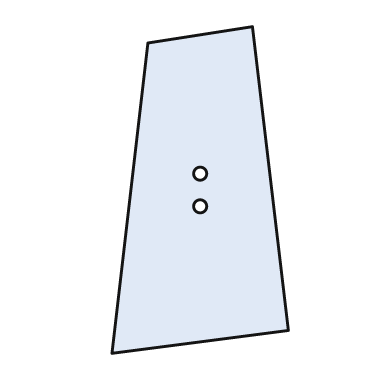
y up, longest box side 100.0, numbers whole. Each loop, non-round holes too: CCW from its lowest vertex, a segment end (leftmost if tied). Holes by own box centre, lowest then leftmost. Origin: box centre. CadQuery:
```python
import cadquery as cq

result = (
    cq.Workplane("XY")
    .moveTo(-27.0, -50.0)
    .lineTo(27.0, -43.0)
    .lineTo(16.0, 50.0)
    .lineTo(-16.0, 45.0)
    .close()
    .moveTo(0.0, -5.0)
    .circle(2.0)
    .moveTo(0.0, 5.0)
    .circle(2.0)
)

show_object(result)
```